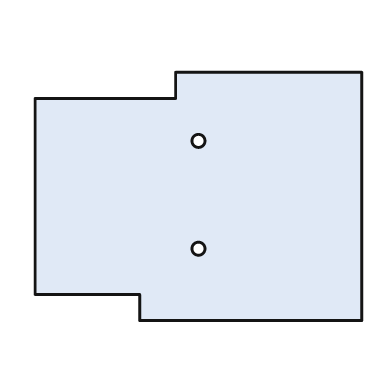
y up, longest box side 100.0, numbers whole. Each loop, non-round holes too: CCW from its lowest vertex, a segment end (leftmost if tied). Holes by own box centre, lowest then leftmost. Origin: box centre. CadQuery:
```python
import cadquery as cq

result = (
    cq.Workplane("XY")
    .moveTo(-18.0, -38.0)
    .lineTo(50.0, -38.0)
    .lineTo(50.0, 38.0)
    .lineTo(-7.0, 38.0)
    .lineTo(-7.0, 30.0)
    .lineTo(-50.0, 30.0)
    .lineTo(-50.0, -30.0)
    .lineTo(-18.0, -30.0)
    .close()
    .moveTo(0.0, -16.0)
    .circle(2.0)
    .moveTo(0.0, 17.0)
    .circle(2.0)
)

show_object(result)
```